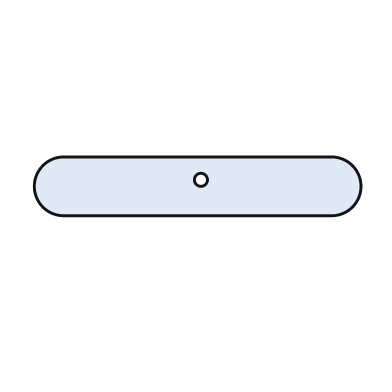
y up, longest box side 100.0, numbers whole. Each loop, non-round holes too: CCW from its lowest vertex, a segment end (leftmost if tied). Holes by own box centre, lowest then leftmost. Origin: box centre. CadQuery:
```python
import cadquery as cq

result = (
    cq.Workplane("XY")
    .moveTo(-41.0, -9.0)
    .lineTo(41.0, -9.0)
    .threePointArc((50.0, 0.0), (41.0, 9.0))
    .lineTo(-41.0, 9.0)
    .threePointArc((-50.0, 0.0), (-41.0, -9.0))
    .close()
    .moveTo(1.0, 2.0)
    .circle(2.0)
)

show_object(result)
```